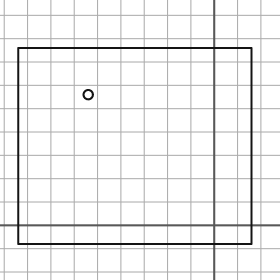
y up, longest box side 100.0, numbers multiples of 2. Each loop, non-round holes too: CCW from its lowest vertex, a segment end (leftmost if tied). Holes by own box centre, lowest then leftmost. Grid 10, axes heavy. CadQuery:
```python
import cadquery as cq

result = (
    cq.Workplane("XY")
    .moveTo(-84.0, -8.0)
    .lineTo(16.0, -8.0)
    .lineTo(16.0, 76.0)
    .lineTo(-84.0, 76.0)
    .close()
    .moveTo(-54.0, 56.0)
    .circle(2.0)
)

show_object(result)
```